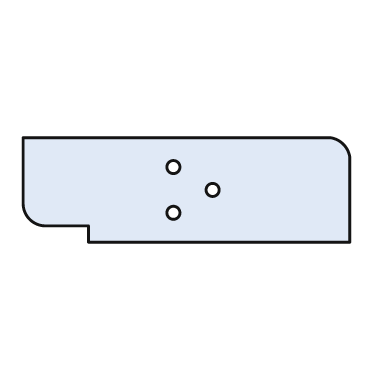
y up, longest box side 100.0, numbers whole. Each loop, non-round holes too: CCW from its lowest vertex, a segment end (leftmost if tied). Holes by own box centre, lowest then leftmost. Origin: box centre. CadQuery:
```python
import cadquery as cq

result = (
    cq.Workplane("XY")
    .moveTo(-30.0, -16.0)
    .lineTo(50.0, -16.0)
    .lineTo(50.0, 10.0)
    .threePointArc((48.0, 14.0), (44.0, 16.0))
    .lineTo(-50.0, 16.0)
    .lineTo(-50.0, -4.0)
    .threePointArc((-48.0, -9.0), (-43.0, -11.0))
    .lineTo(-30.0, -11.0)
    .close()
    .moveTo(-4.0, -7.0)
    .circle(2.0)
    .moveTo(8.0, 0.0)
    .circle(2.0)
    .moveTo(-4.0, 7.0)
    .circle(2.0)
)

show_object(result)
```